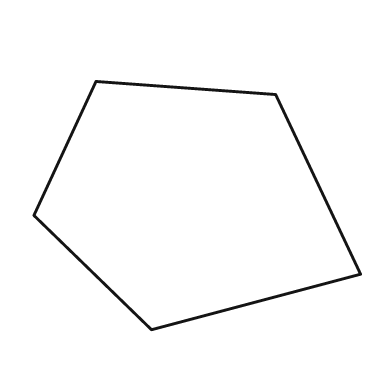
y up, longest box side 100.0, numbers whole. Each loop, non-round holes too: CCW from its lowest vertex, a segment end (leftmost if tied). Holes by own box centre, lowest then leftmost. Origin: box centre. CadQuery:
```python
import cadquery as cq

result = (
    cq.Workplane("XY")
    .moveTo(-14.0, -38.0)
    .lineTo(50.0, -21.0)
    .lineTo(24.0, 34.0)
    .lineTo(-31.0, 38.0)
    .lineTo(-50.0, -3.0)
    .close()
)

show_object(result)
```